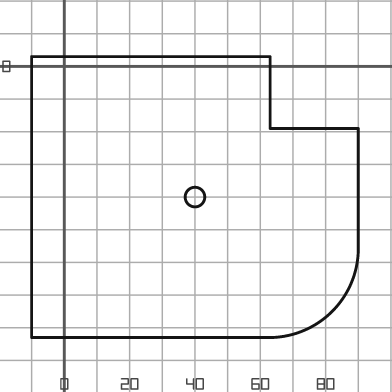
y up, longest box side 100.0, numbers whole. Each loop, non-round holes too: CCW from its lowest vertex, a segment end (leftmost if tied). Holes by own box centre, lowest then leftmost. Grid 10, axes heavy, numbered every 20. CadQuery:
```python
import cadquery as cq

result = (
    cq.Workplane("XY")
    .moveTo(-10.0, -83.0)
    .lineTo(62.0, -83.0)
    .threePointArc((82.0, -75.0), (90.0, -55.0))
    .lineTo(90.0, -19.0)
    .lineTo(63.0, -19.0)
    .lineTo(63.0, 3.0)
    .lineTo(-10.0, 3.0)
    .close()
    .moveTo(40.0, -40.0)
    .circle(3.0)
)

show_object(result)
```